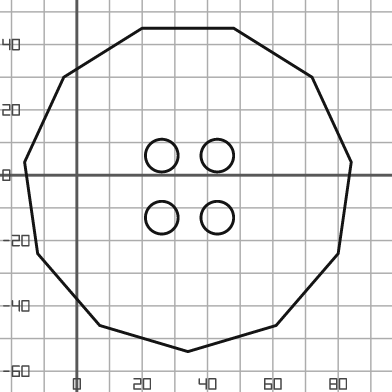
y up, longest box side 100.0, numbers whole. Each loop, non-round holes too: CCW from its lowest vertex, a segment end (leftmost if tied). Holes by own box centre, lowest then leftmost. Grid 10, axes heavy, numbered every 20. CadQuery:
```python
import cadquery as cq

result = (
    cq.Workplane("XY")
    .moveTo(34.0, -54.0)
    .lineTo(61.0, -46.0)
    .lineTo(80.0, -24.0)
    .lineTo(84.0, 4.0)
    .lineTo(72.0, 30.0)
    .lineTo(48.0, 45.0)
    .lineTo(20.0, 45.0)
    .lineTo(-4.0, 30.0)
    .lineTo(-16.0, 4.0)
    .lineTo(-12.0, -24.0)
    .lineTo(7.0, -46.0)
    .close()
    .moveTo(26.0, -13.0)
    .circle(5.0)
    .moveTo(43.0, -13.0)
    .circle(5.0)
    .moveTo(26.0, 6.0)
    .circle(5.0)
    .moveTo(43.0, 6.0)
    .circle(5.0)
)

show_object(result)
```